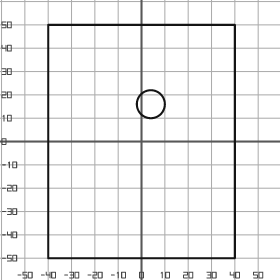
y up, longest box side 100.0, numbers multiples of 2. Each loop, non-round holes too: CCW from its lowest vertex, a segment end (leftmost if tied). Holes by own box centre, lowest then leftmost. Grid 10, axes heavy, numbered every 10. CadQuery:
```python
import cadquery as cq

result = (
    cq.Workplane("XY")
    .moveTo(-40.0, -50.0)
    .lineTo(40.0, -50.0)
    .lineTo(40.0, 50.0)
    .lineTo(-40.0, 50.0)
    .close()
    .moveTo(4.0, 16.0)
    .circle(6.0)
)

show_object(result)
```